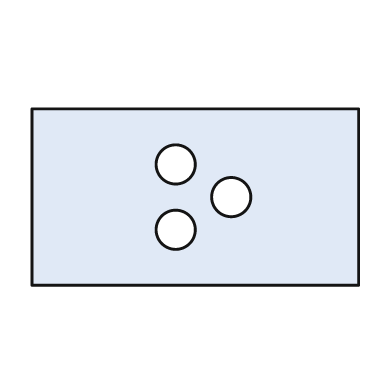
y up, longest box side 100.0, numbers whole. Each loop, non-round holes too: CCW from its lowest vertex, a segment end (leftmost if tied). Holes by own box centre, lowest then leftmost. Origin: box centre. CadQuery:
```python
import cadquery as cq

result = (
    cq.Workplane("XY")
    .moveTo(-50.0, -27.0)
    .lineTo(50.0, -27.0)
    .lineTo(50.0, 27.0)
    .lineTo(-50.0, 27.0)
    .close()
    .moveTo(-6.0, -10.0)
    .circle(6.0)
    .moveTo(11.0, 0.0)
    .circle(6.0)
    .moveTo(-6.0, 10.0)
    .circle(6.0)
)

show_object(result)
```